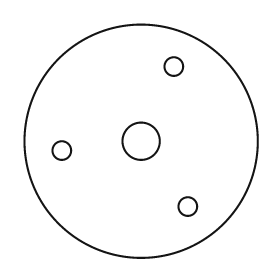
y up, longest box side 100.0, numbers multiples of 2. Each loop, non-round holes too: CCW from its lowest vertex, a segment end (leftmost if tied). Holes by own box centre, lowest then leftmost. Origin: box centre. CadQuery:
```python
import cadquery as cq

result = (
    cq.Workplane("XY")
    .moveTo(0.0, 0.0)
    .circle(50.0)
    .moveTo(20.0, -28.0)
    .circle(4.0)
    .moveTo(-34.0, -4.0)
    .circle(4.0)
    .moveTo(0.0, 0.0)
    .circle(8.0)
    .moveTo(14.0, 32.0)
    .circle(4.0)
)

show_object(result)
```